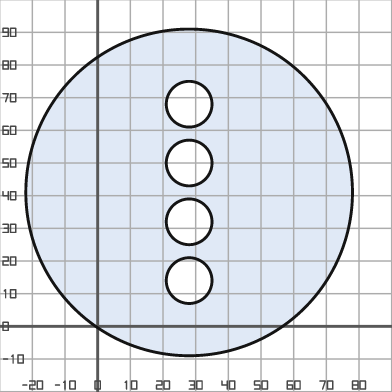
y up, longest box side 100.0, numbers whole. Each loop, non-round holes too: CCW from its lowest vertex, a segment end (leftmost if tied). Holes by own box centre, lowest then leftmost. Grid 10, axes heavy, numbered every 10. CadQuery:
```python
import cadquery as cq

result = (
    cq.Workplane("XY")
    .moveTo(28.0, 41.0)
    .circle(50.0)
    .moveTo(28.0, 14.0)
    .circle(7.0)
    .moveTo(28.0, 32.0)
    .circle(7.0)
    .moveTo(28.0, 50.0)
    .circle(7.0)
    .moveTo(28.0, 68.0)
    .circle(7.0)
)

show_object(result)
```